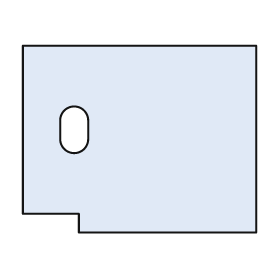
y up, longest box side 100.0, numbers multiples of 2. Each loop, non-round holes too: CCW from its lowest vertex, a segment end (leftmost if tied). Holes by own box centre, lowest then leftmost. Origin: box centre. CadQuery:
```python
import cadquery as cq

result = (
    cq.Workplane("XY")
    .moveTo(-26.0, -40.0)
    .lineTo(50.0, -40.0)
    .lineTo(50.0, 40.0)
    .lineTo(-50.0, 40.0)
    .lineTo(-50.0, -32.0)
    .lineTo(-26.0, -32.0)
    .close()
    .moveTo(-34.0, 0.0)
    .threePointArc((-28.0, -6.0), (-22.0, 0.0))
    .lineTo(-22.0, 8.0)
    .threePointArc((-28.0, 14.0), (-34.0, 8.0))
    .close()
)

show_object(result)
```